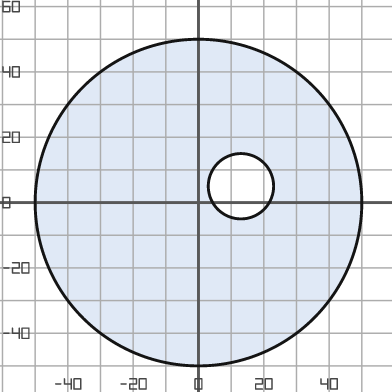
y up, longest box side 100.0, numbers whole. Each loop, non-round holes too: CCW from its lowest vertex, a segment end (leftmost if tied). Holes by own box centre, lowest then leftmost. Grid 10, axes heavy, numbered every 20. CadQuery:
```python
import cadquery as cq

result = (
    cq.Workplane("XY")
    .moveTo(0.0, 0.0)
    .circle(50.0)
    .moveTo(13.0, 5.0)
    .circle(10.0)
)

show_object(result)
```